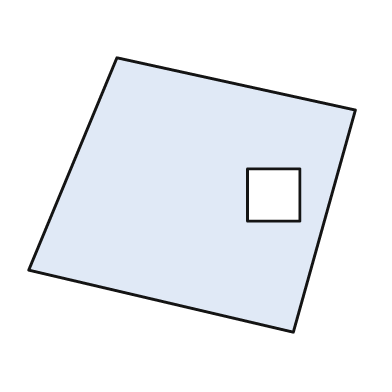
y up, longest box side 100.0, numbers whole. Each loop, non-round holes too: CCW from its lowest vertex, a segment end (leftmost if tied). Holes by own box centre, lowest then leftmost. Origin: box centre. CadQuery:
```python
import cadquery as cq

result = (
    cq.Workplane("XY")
    .moveTo(31.0, -42.0)
    .lineTo(50.0, 26.0)
    .lineTo(-23.0, 42.0)
    .lineTo(-50.0, -23.0)
    .close()
    .moveTo(17.0, -8.0)
    .lineTo(33.0, -8.0)
    .lineTo(33.0, 8.0)
    .lineTo(17.0, 8.0)
    .close()
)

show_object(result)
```